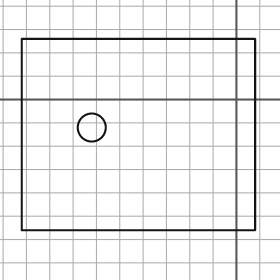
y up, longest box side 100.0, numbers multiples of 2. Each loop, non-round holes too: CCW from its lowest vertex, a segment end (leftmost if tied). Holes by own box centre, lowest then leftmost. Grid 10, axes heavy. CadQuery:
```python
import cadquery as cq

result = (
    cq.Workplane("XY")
    .moveTo(-92.0, -56.0)
    .lineTo(8.0, -56.0)
    .lineTo(8.0, 26.0)
    .lineTo(-92.0, 26.0)
    .close()
    .moveTo(-62.0, -12.0)
    .circle(6.0)
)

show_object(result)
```